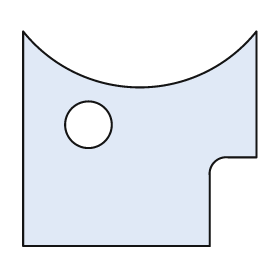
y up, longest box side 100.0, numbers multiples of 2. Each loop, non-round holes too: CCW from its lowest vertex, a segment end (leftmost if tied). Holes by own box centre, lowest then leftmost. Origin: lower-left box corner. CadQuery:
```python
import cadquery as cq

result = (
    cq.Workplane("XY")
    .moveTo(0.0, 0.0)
    .lineTo(80.0, 0.0)
    .lineTo(80.0, 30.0)
    .threePointArc((82.0, 36.0), (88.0, 38.0))
    .lineTo(100.0, 38.0)
    .lineTo(100.0, 92.0)
    .threePointArc((50.0, 68.0), (0.0, 92.0))
    .close()
    .moveTo(28.0, 52.0)
    .circle(10.0)
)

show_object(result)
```